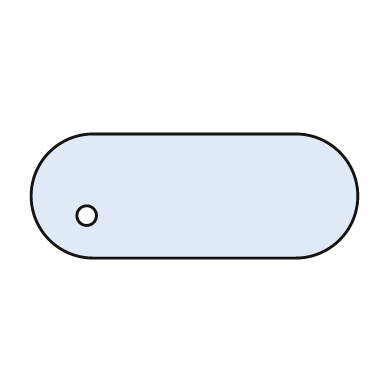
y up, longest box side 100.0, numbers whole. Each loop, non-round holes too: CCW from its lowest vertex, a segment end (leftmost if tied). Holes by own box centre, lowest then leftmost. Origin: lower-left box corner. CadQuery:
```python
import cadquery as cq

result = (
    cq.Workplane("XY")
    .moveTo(19.0, 0.0)
    .lineTo(81.0, 0.0)
    .threePointArc((100.0, 19.0), (81.0, 38.0))
    .lineTo(19.0, 38.0)
    .threePointArc((0.0, 19.0), (19.0, 0.0))
    .close()
    .moveTo(17.0, 13.0)
    .circle(3.0)
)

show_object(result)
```